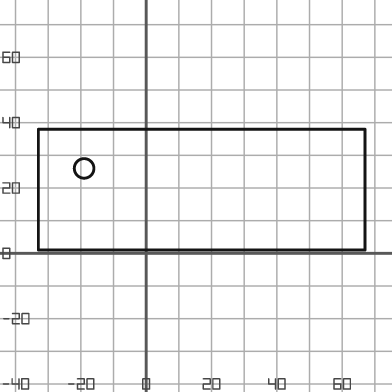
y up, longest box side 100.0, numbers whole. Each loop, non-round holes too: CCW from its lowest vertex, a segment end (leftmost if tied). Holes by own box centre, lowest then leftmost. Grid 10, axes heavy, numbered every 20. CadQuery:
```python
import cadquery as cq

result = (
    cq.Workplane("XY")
    .moveTo(-33.0, 1.0)
    .lineTo(67.0, 1.0)
    .lineTo(67.0, 38.0)
    .lineTo(-33.0, 38.0)
    .close()
    .moveTo(-19.0, 26.0)
    .circle(3.0)
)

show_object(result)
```